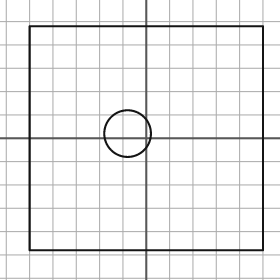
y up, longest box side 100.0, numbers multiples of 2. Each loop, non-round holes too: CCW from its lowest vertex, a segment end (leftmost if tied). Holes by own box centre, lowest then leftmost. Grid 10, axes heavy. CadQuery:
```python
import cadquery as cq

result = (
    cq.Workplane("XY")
    .moveTo(-50.0, -48.0)
    .lineTo(50.0, -48.0)
    .lineTo(50.0, 48.0)
    .lineTo(-50.0, 48.0)
    .close()
    .moveTo(-8.0, 2.0)
    .circle(10.0)
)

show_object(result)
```